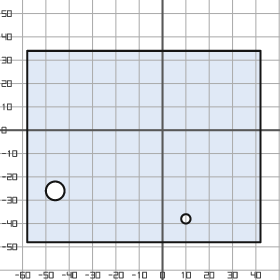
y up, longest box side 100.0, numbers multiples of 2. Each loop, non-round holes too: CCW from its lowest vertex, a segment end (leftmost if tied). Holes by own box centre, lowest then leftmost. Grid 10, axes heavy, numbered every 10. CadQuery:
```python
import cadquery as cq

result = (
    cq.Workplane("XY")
    .moveTo(-58.0, -48.0)
    .lineTo(42.0, -48.0)
    .lineTo(42.0, 34.0)
    .lineTo(-58.0, 34.0)
    .close()
    .moveTo(10.0, -38.0)
    .circle(2.0)
    .moveTo(-46.0, -26.0)
    .circle(4.0)
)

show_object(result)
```